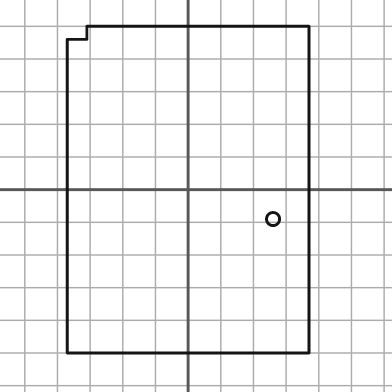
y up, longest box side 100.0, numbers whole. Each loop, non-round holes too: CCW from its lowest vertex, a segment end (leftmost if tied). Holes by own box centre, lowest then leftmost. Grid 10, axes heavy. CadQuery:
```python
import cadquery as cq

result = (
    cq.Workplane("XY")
    .moveTo(-37.0, -50.0)
    .lineTo(37.0, -50.0)
    .lineTo(37.0, 50.0)
    .lineTo(-31.0, 50.0)
    .lineTo(-31.0, 46.0)
    .lineTo(-37.0, 46.0)
    .close()
    .moveTo(26.0, -9.0)
    .circle(2.0)
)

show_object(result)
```